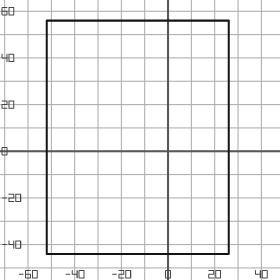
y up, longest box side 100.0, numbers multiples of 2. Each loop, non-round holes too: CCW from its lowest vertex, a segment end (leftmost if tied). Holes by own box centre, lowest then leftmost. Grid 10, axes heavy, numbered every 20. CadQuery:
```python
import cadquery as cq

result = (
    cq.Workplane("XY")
    .moveTo(-52.0, -44.0)
    .lineTo(26.0, -44.0)
    .lineTo(26.0, 56.0)
    .lineTo(-52.0, 56.0)
    .close()
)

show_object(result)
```